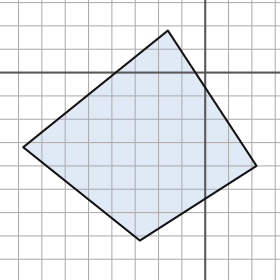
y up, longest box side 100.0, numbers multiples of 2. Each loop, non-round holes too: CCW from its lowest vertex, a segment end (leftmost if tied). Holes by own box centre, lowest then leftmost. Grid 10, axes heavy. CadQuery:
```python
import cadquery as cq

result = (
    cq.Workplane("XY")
    .moveTo(-28.0, -72.0)
    .lineTo(22.0, -40.0)
    .lineTo(-16.0, 18.0)
    .lineTo(-78.0, -32.0)
    .close()
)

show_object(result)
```